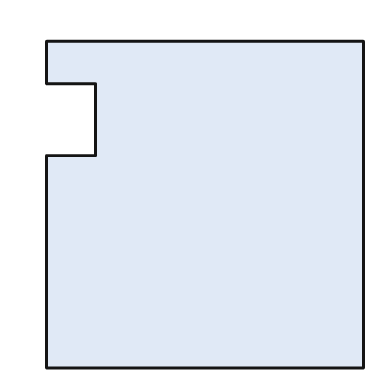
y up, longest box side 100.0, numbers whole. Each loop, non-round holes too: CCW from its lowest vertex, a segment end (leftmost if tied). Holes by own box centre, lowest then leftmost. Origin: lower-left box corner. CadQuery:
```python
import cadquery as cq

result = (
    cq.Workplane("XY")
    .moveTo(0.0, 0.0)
    .lineTo(97.0, 0.0)
    .lineTo(97.0, 100.0)
    .lineTo(0.0, 100.0)
    .lineTo(0.0, 87.0)
    .lineTo(15.0, 87.0)
    .lineTo(15.0, 65.0)
    .lineTo(0.0, 65.0)
    .close()
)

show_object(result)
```